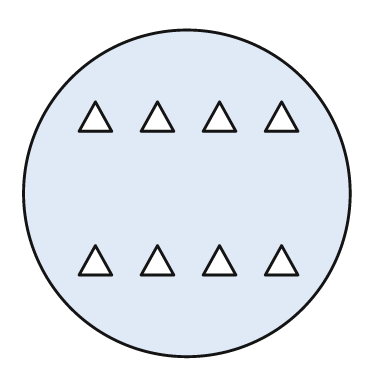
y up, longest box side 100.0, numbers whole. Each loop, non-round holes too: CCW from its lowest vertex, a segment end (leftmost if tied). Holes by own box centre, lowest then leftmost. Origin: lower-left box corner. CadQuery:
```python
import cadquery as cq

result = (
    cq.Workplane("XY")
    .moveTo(50.0, 50.0)
    .circle(50.0)
    .moveTo(17.0, 25.0)
    .lineTo(27.0, 25.0)
    .lineTo(22.0, 34.0)
    .close()
    .moveTo(36.0, 25.0)
    .lineTo(46.0, 25.0)
    .lineTo(41.0, 34.0)
    .close()
    .moveTo(55.0, 25.0)
    .lineTo(65.0, 25.0)
    .lineTo(60.0, 34.0)
    .close()
    .moveTo(74.0, 25.0)
    .lineTo(84.0, 25.0)
    .lineTo(79.0, 34.0)
    .close()
    .moveTo(17.0, 69.0)
    .lineTo(27.0, 69.0)
    .lineTo(22.0, 78.0)
    .close()
    .moveTo(36.0, 69.0)
    .lineTo(46.0, 69.0)
    .lineTo(41.0, 78.0)
    .close()
    .moveTo(55.0, 69.0)
    .lineTo(65.0, 69.0)
    .lineTo(60.0, 78.0)
    .close()
    .moveTo(74.0, 69.0)
    .lineTo(84.0, 69.0)
    .lineTo(79.0, 78.0)
    .close()
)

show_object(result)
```